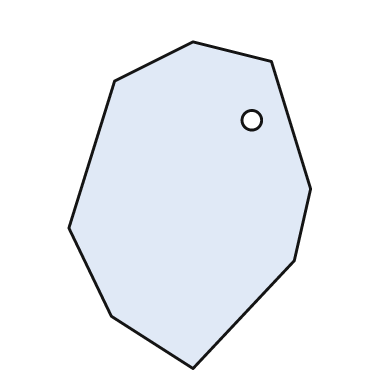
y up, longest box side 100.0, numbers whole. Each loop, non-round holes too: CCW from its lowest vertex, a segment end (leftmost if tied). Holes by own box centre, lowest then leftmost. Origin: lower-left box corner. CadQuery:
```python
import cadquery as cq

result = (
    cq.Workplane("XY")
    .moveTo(38.0, 0.0)
    .lineTo(69.0, 33.0)
    .lineTo(74.0, 55.0)
    .lineTo(62.0, 94.0)
    .lineTo(38.0, 100.0)
    .lineTo(14.0, 88.0)
    .lineTo(0.0, 43.0)
    .lineTo(13.0, 16.0)
    .close()
    .moveTo(56.0, 76.0)
    .circle(3.0)
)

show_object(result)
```